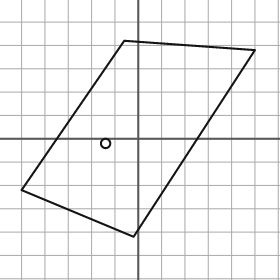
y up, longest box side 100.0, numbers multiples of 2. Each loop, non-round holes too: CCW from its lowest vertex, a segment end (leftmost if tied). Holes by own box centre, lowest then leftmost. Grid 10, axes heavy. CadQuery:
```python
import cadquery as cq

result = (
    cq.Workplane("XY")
    .moveTo(-2.0, -42.0)
    .lineTo(50.0, 38.0)
    .lineTo(-6.0, 42.0)
    .lineTo(-50.0, -22.0)
    .close()
    .moveTo(-14.0, -2.0)
    .circle(2.0)
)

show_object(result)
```